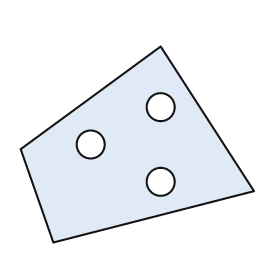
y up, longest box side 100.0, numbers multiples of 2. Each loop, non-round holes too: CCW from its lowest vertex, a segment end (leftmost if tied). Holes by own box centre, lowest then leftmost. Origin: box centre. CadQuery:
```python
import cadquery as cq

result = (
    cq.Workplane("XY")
    .moveTo(-36.0, -42.0)
    .lineTo(50.0, -20.0)
    .lineTo(10.0, 42.0)
    .lineTo(-50.0, -2.0)
    .close()
    .moveTo(10.0, -16.0)
    .circle(6.0)
    .moveTo(-20.0, 0.0)
    .circle(6.0)
    .moveTo(10.0, 16.0)
    .circle(6.0)
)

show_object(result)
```